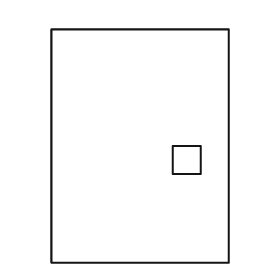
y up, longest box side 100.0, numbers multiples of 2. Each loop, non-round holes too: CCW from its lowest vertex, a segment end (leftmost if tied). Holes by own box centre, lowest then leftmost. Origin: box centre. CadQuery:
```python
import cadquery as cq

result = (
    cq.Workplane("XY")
    .moveTo(-38.0, -50.0)
    .lineTo(38.0, -50.0)
    .lineTo(38.0, 50.0)
    .lineTo(-38.0, 50.0)
    .close()
    .moveTo(14.0, -12.0)
    .lineTo(26.0, -12.0)
    .lineTo(26.0, 0.0)
    .lineTo(14.0, 0.0)
    .close()
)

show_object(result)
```